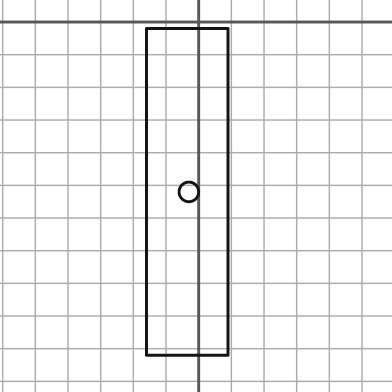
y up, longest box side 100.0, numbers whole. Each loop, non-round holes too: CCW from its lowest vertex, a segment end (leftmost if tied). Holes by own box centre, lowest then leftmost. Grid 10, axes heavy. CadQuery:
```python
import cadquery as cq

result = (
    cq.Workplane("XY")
    .moveTo(-16.0, -102.0)
    .lineTo(9.0, -102.0)
    .lineTo(9.0, -2.0)
    .lineTo(-16.0, -2.0)
    .close()
    .moveTo(-3.0, -52.0)
    .circle(3.0)
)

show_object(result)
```